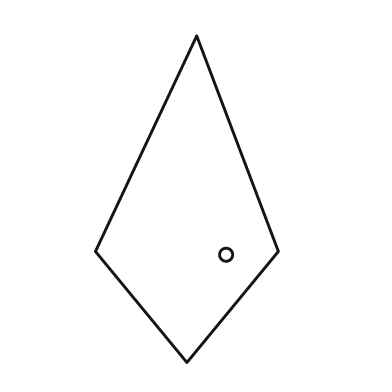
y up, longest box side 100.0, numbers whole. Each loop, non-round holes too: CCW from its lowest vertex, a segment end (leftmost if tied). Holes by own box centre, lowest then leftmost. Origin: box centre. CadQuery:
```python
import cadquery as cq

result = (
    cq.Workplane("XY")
    .moveTo(0.0, -50.0)
    .lineTo(28.0, -16.0)
    .lineTo(3.0, 50.0)
    .lineTo(-28.0, -16.0)
    .close()
    .moveTo(12.0, -17.0)
    .circle(2.0)
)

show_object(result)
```